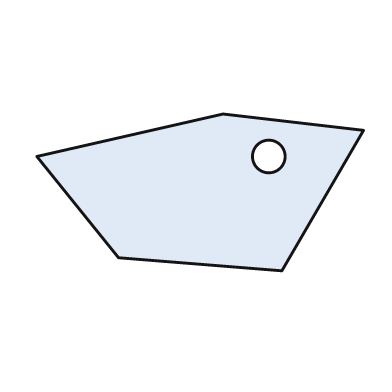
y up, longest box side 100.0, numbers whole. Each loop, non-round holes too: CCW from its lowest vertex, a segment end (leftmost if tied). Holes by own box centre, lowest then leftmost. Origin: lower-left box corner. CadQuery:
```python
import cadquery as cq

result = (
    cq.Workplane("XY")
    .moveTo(75.0, 0.0)
    .lineTo(100.0, 43.0)
    .lineTo(57.0, 48.0)
    .lineTo(0.0, 35.0)
    .lineTo(25.0, 4.0)
    .close()
    .moveTo(71.0, 35.0)
    .circle(5.0)
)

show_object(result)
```